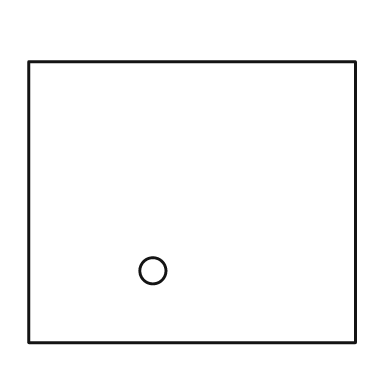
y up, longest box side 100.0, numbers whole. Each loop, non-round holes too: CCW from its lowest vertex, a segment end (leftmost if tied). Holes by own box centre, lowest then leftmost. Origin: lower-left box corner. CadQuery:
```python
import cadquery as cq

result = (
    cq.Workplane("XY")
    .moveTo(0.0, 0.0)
    .lineTo(100.0, 0.0)
    .lineTo(100.0, 86.0)
    .lineTo(0.0, 86.0)
    .close()
    .moveTo(38.0, 22.0)
    .circle(4.0)
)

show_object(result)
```